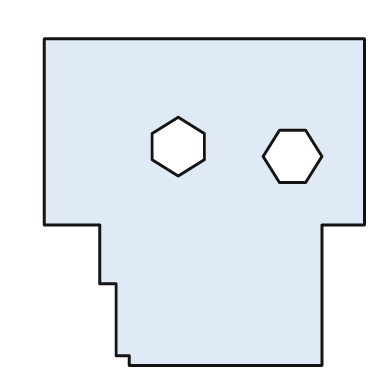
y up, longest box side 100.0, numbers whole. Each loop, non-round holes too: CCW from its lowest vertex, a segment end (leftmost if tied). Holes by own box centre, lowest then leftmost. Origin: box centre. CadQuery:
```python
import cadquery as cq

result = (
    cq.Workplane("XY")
    .moveTo(-23.0, -50.0)
    .lineTo(36.0, -50.0)
    .lineTo(36.0, -7.0)
    .lineTo(49.0, -7.0)
    .lineTo(49.0, 50.0)
    .lineTo(-49.0, 50.0)
    .lineTo(-49.0, -7.0)
    .lineTo(-32.0, -7.0)
    .lineTo(-32.0, -25.0)
    .lineTo(-27.0, -25.0)
    .lineTo(-27.0, -47.0)
    .lineTo(-23.0, -47.0)
    .close()
    .moveTo(23.0, 6.0)
    .lineTo(31.0, 6.0)
    .lineTo(36.0, 14.0)
    .lineTo(31.0, 22.0)
    .lineTo(23.0, 22.0)
    .lineTo(18.0, 14.0)
    .close()
    .moveTo(-8.0, 8.0)
    .lineTo(0.0, 13.0)
    .lineTo(0.0, 21.0)
    .lineTo(-8.0, 26.0)
    .lineTo(-16.0, 21.0)
    .lineTo(-16.0, 13.0)
    .close()
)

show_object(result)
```